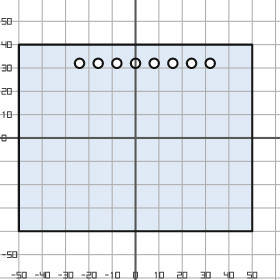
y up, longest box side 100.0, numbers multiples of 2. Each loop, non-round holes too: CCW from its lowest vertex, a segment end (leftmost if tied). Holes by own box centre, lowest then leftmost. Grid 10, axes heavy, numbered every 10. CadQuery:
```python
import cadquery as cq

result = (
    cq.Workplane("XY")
    .moveTo(-50.0, -40.0)
    .lineTo(50.0, -40.0)
    .lineTo(50.0, 40.0)
    .lineTo(-50.0, 40.0)
    .close()
    .moveTo(-24.0, 32.0)
    .circle(2.0)
    .moveTo(-16.0, 32.0)
    .circle(2.0)
    .moveTo(-8.0, 32.0)
    .circle(2.0)
    .moveTo(0.0, 32.0)
    .circle(2.0)
    .moveTo(8.0, 32.0)
    .circle(2.0)
    .moveTo(16.0, 32.0)
    .circle(2.0)
    .moveTo(24.0, 32.0)
    .circle(2.0)
    .moveTo(32.0, 32.0)
    .circle(2.0)
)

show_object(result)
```